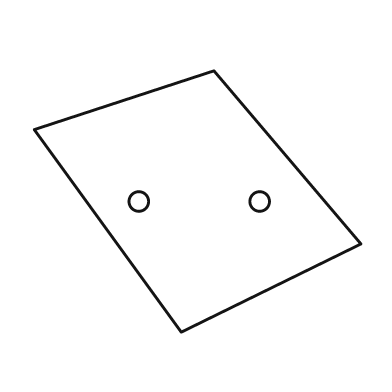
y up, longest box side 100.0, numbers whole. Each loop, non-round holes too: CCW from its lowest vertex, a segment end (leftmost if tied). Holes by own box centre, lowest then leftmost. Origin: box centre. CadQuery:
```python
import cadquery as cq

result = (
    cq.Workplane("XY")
    .moveTo(-5.0, -40.0)
    .lineTo(50.0, -13.0)
    .lineTo(5.0, 40.0)
    .lineTo(-50.0, 22.0)
    .close()
    .moveTo(-18.0, 0.0)
    .circle(3.0)
    .moveTo(19.0, 0.0)
    .circle(3.0)
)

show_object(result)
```